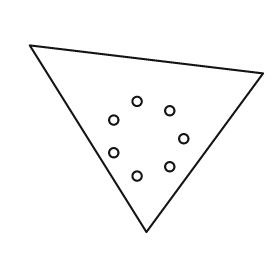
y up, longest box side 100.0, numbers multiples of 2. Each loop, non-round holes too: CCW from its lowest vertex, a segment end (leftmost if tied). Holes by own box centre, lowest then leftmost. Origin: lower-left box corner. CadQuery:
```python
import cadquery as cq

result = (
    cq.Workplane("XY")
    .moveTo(50.0, 0.0)
    .lineTo(100.0, 68.0)
    .lineTo(0.0, 80.0)
    .close()
    .moveTo(46.0, 24.0)
    .circle(2.0)
    .moveTo(60.0, 28.0)
    .circle(2.0)
    .moveTo(36.0, 34.0)
    .circle(2.0)
    .moveTo(66.0, 40.0)
    .circle(2.0)
    .moveTo(36.0, 48.0)
    .circle(2.0)
    .moveTo(60.0, 52.0)
    .circle(2.0)
    .moveTo(46.0, 56.0)
    .circle(2.0)
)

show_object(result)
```